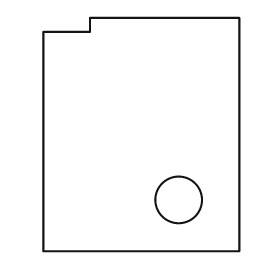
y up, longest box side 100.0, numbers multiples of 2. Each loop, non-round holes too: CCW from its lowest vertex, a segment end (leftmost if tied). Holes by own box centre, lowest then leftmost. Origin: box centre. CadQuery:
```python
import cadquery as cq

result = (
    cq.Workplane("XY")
    .moveTo(-42.0, -50.0)
    .lineTo(42.0, -50.0)
    .lineTo(42.0, 50.0)
    .lineTo(-22.0, 50.0)
    .lineTo(-22.0, 44.0)
    .lineTo(-42.0, 44.0)
    .close()
    .moveTo(16.0, -28.0)
    .circle(10.0)
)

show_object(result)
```